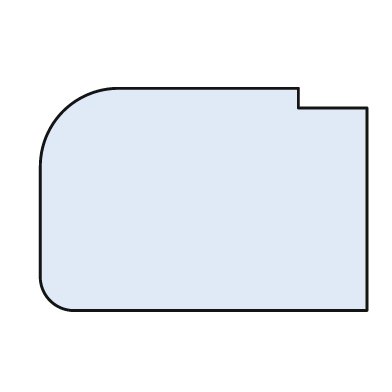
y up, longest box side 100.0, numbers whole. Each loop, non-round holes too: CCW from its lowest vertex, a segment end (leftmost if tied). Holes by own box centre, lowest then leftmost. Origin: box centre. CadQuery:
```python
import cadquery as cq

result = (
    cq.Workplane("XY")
    .moveTo(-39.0, -34.0)
    .lineTo(50.0, -34.0)
    .lineTo(50.0, 28.0)
    .lineTo(29.0, 28.0)
    .lineTo(29.0, 34.0)
    .lineTo(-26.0, 34.0)
    .threePointArc((-43.0, 27.0), (-50.0, 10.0))
    .lineTo(-50.0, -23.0)
    .threePointArc((-47.0, -31.0), (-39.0, -34.0))
    .close()
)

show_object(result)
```